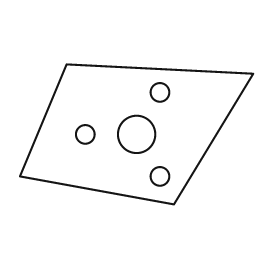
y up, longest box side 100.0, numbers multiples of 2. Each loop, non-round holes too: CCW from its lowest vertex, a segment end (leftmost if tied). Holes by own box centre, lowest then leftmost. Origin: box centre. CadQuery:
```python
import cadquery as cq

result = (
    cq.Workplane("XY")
    .moveTo(16.0, -30.0)
    .lineTo(50.0, 26.0)
    .lineTo(-30.0, 30.0)
    .lineTo(-50.0, -18.0)
    .close()
    .moveTo(10.0, -18.0)
    .circle(4.0)
    .moveTo(-22.0, 0.0)
    .circle(4.0)
    .moveTo(0.0, 0.0)
    .circle(8.0)
    .moveTo(10.0, 18.0)
    .circle(4.0)
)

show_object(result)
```